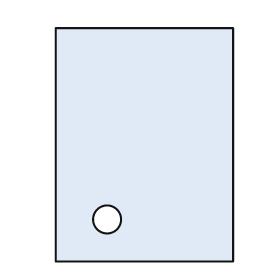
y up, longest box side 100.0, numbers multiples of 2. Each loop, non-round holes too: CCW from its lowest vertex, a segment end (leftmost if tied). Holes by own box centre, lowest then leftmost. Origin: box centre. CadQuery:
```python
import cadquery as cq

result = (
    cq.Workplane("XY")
    .moveTo(-38.0, -50.0)
    .lineTo(38.0, -50.0)
    .lineTo(38.0, 50.0)
    .lineTo(-38.0, 50.0)
    .close()
    .moveTo(-16.0, -32.0)
    .circle(6.0)
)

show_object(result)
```